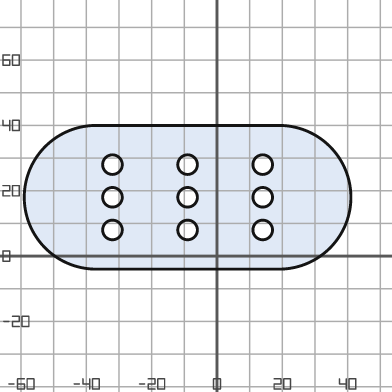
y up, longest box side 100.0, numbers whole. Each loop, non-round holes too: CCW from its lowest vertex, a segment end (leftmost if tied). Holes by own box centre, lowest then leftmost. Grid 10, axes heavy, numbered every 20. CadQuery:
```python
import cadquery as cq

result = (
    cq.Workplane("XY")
    .moveTo(-37.0, -4.0)
    .lineTo(19.0, -4.0)
    .threePointArc((41.0, 18.0), (19.0, 40.0))
    .lineTo(-37.0, 40.0)
    .threePointArc((-59.0, 18.0), (-37.0, -4.0))
    .close()
    .moveTo(-32.0, 8.0)
    .circle(3.0)
    .moveTo(-9.0, 8.0)
    .circle(3.0)
    .moveTo(14.0, 8.0)
    .circle(3.0)
    .moveTo(-32.0, 18.0)
    .circle(3.0)
    .moveTo(-9.0, 18.0)
    .circle(3.0)
    .moveTo(14.0, 18.0)
    .circle(3.0)
    .moveTo(-32.0, 28.0)
    .circle(3.0)
    .moveTo(-9.0, 28.0)
    .circle(3.0)
    .moveTo(14.0, 28.0)
    .circle(3.0)
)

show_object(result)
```